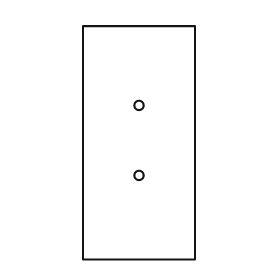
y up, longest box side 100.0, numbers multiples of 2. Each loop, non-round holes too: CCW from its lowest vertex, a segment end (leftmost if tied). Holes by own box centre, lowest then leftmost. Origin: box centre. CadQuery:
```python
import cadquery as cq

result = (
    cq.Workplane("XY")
    .moveTo(-24.0, -50.0)
    .lineTo(24.0, -50.0)
    .lineTo(24.0, 50.0)
    .lineTo(-24.0, 50.0)
    .close()
    .moveTo(0.0, -14.0)
    .circle(2.0)
    .moveTo(0.0, 16.0)
    .circle(2.0)
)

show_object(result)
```